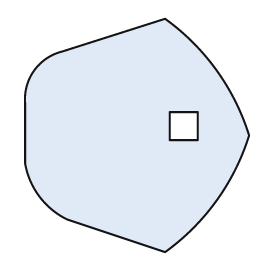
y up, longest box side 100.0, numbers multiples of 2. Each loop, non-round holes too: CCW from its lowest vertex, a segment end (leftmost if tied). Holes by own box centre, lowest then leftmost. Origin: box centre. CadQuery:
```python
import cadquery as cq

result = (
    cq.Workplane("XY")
    .moveTo(12.0, -50.0)
    .threePointArc((34.0, -28.0), (48.0, 0.0))
    .threePointArc((34.0, 28.0), (12.0, 50.0))
    .lineTo(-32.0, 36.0)
    .threePointArc((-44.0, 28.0), (-48.0, 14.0))
    .lineTo(-48.0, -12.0)
    .threePointArc((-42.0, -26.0), (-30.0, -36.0))
    .close()
    .moveTo(14.0, -2.0)
    .lineTo(26.0, -2.0)
    .lineTo(26.0, 10.0)
    .lineTo(14.0, 10.0)
    .close()
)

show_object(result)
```